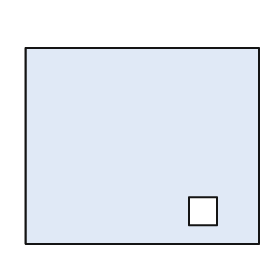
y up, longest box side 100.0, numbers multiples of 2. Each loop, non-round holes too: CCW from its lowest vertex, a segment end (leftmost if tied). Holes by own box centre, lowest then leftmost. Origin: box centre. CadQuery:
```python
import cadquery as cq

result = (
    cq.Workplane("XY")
    .moveTo(-50.0, -42.0)
    .lineTo(50.0, -42.0)
    .lineTo(50.0, 42.0)
    .lineTo(-50.0, 42.0)
    .close()
    .moveTo(20.0, -34.0)
    .lineTo(32.0, -34.0)
    .lineTo(32.0, -22.0)
    .lineTo(20.0, -22.0)
    .close()
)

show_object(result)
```